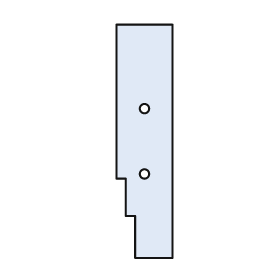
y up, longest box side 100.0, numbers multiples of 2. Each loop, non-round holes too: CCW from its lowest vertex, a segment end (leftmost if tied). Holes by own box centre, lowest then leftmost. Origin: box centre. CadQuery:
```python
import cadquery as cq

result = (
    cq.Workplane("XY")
    .moveTo(-4.0, -50.0)
    .lineTo(12.0, -50.0)
    .lineTo(12.0, 50.0)
    .lineTo(-12.0, 50.0)
    .lineTo(-12.0, -16.0)
    .lineTo(-8.0, -16.0)
    .lineTo(-8.0, -32.0)
    .lineTo(-4.0, -32.0)
    .close()
    .moveTo(0.0, -14.0)
    .circle(2.0)
    .moveTo(0.0, 14.0)
    .circle(2.0)
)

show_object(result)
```